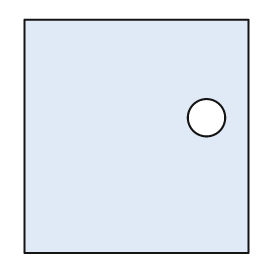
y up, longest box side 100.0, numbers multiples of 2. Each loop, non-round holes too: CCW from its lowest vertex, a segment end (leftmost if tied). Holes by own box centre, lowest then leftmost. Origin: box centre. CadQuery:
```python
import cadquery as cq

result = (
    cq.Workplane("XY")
    .moveTo(-48.0, -50.0)
    .lineTo(48.0, -50.0)
    .lineTo(48.0, 50.0)
    .lineTo(-48.0, 50.0)
    .close()
    .moveTo(30.0, 8.0)
    .circle(8.0)
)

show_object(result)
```